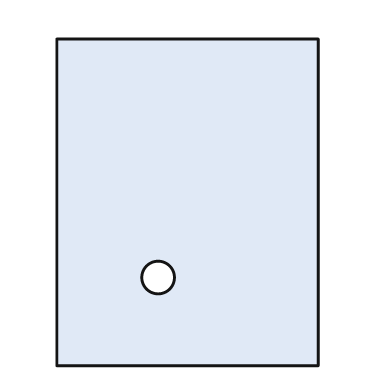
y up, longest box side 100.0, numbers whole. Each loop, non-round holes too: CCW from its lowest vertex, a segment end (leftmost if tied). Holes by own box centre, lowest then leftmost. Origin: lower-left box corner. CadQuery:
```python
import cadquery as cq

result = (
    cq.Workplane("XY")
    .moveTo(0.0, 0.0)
    .lineTo(80.0, 0.0)
    .lineTo(80.0, 100.0)
    .lineTo(0.0, 100.0)
    .close()
    .moveTo(31.0, 27.0)
    .circle(5.0)
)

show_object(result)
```